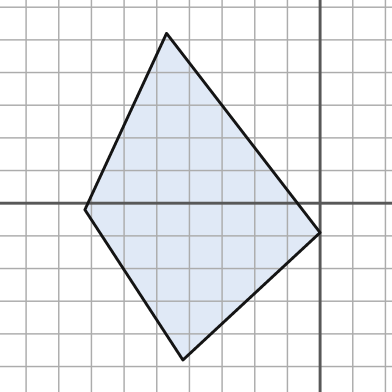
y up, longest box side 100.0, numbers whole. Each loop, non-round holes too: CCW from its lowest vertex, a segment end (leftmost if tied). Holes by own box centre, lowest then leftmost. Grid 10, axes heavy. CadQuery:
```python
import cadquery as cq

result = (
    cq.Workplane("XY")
    .moveTo(-42.0, -48.0)
    .lineTo(0.0, -9.0)
    .lineTo(-47.0, 52.0)
    .lineTo(-72.0, -2.0)
    .close()
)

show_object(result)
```